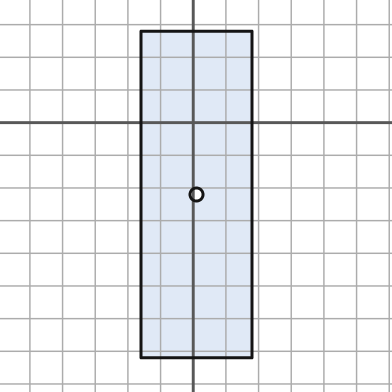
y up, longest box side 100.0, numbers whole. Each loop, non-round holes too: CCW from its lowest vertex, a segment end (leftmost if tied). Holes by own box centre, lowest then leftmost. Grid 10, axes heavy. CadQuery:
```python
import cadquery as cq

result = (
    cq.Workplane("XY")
    .moveTo(-16.0, -72.0)
    .lineTo(18.0, -72.0)
    .lineTo(18.0, 28.0)
    .lineTo(-16.0, 28.0)
    .close()
    .moveTo(1.0, -22.0)
    .circle(2.0)
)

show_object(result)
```